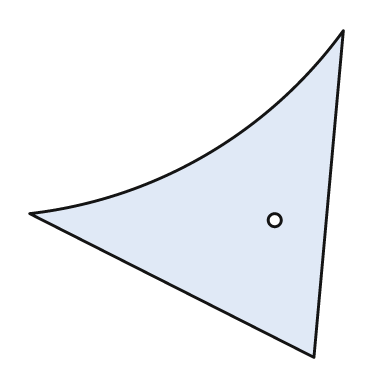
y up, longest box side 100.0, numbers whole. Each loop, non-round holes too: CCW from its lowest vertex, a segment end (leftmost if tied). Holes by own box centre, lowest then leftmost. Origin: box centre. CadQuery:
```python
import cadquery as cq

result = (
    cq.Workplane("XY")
    .moveTo(39.0, -50.0)
    .lineTo(48.0, 50.0)
    .threePointArc((6.0, 12.0), (-48.0, -6.0))
    .close()
    .moveTo(27.0, -8.0)
    .circle(2.0)
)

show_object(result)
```